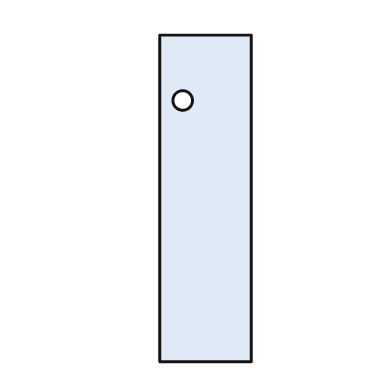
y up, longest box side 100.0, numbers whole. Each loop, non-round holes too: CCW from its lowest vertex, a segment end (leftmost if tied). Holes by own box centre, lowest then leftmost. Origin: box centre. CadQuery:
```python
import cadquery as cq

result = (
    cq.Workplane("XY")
    .moveTo(-14.0, -50.0)
    .lineTo(14.0, -50.0)
    .lineTo(14.0, 50.0)
    .lineTo(-14.0, 50.0)
    .close()
    .moveTo(-7.0, 30.0)
    .circle(3.0)
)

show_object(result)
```